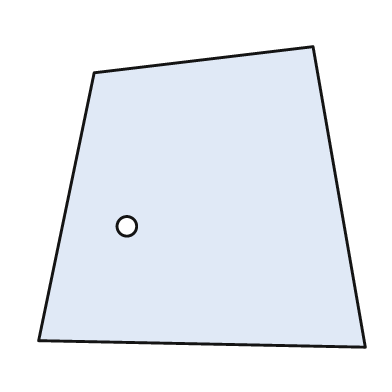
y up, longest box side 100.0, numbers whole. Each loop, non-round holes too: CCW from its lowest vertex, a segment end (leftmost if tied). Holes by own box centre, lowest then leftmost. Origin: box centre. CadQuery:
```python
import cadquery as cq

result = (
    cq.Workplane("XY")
    .moveTo(50.0, -46.0)
    .lineTo(34.0, 46.0)
    .lineTo(-33.0, 38.0)
    .lineTo(-50.0, -44.0)
    .close()
    .moveTo(-23.0, -9.0)
    .circle(3.0)
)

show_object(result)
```